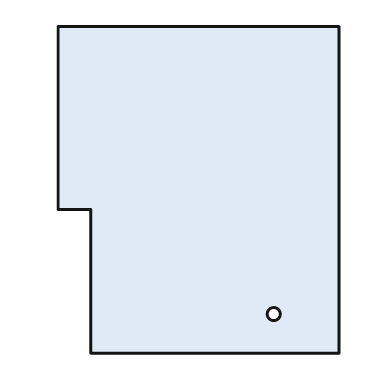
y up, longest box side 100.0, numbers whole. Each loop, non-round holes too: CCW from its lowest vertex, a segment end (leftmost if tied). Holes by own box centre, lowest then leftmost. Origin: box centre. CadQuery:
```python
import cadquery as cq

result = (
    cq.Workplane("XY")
    .moveTo(-33.0, -50.0)
    .lineTo(43.0, -50.0)
    .lineTo(43.0, 50.0)
    .lineTo(-43.0, 50.0)
    .lineTo(-43.0, -6.0)
    .lineTo(-33.0, -6.0)
    .close()
    .moveTo(23.0, -38.0)
    .circle(2.0)
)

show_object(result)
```